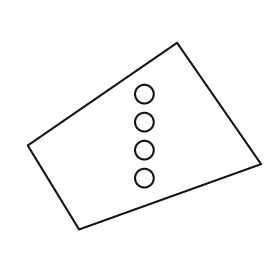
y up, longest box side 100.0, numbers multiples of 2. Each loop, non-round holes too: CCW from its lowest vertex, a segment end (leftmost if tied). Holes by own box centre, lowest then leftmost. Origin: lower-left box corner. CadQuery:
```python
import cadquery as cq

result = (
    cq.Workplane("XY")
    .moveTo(22.0, 0.0)
    .lineTo(100.0, 28.0)
    .lineTo(64.0, 80.0)
    .lineTo(0.0, 36.0)
    .close()
    .moveTo(50.0, 22.0)
    .circle(4.0)
    .moveTo(50.0, 34.0)
    .circle(4.0)
    .moveTo(50.0, 46.0)
    .circle(4.0)
    .moveTo(50.0, 58.0)
    .circle(4.0)
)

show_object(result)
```